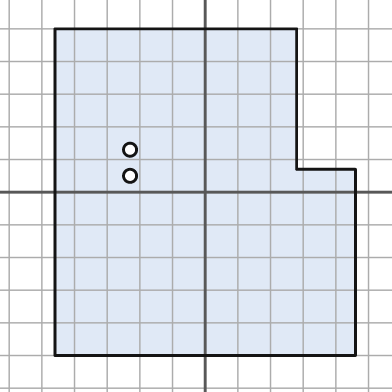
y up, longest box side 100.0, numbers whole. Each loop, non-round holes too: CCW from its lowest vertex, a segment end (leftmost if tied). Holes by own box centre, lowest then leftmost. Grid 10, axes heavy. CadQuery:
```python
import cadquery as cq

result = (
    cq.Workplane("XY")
    .moveTo(-46.0, -50.0)
    .lineTo(46.0, -50.0)
    .lineTo(46.0, 7.0)
    .lineTo(28.0, 7.0)
    .lineTo(28.0, 50.0)
    .lineTo(-46.0, 50.0)
    .close()
    .moveTo(-23.0, 5.0)
    .circle(2.0)
    .moveTo(-23.0, 13.0)
    .circle(2.0)
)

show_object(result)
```